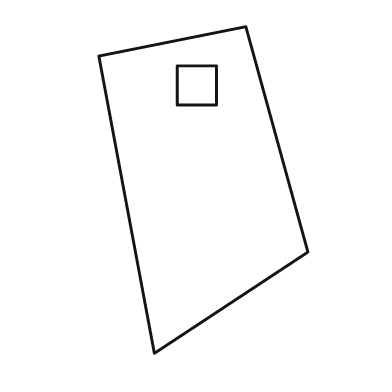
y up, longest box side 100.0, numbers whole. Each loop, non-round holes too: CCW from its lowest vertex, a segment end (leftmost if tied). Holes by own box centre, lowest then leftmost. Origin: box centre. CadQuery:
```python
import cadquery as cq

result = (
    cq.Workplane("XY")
    .moveTo(-15.0, -50.0)
    .lineTo(32.0, -19.0)
    .lineTo(13.0, 50.0)
    .lineTo(-32.0, 41.0)
    .close()
    .moveTo(-8.0, 26.0)
    .lineTo(4.0, 26.0)
    .lineTo(4.0, 38.0)
    .lineTo(-8.0, 38.0)
    .close()
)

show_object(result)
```